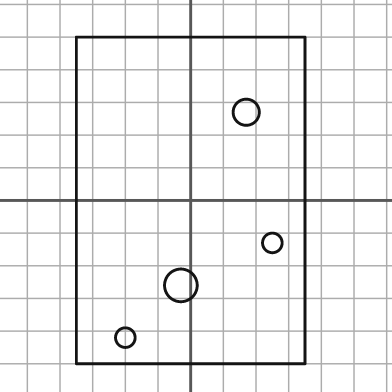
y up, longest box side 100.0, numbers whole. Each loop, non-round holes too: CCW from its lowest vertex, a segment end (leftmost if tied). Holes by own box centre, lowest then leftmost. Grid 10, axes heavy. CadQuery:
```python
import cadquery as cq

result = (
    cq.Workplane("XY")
    .moveTo(-35.0, -50.0)
    .lineTo(35.0, -50.0)
    .lineTo(35.0, 50.0)
    .lineTo(-35.0, 50.0)
    .close()
    .moveTo(-20.0, -42.0)
    .circle(3.0)
    .moveTo(-3.0, -26.0)
    .circle(5.0)
    .moveTo(25.0, -13.0)
    .circle(3.0)
    .moveTo(17.0, 27.0)
    .circle(4.0)
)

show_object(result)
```